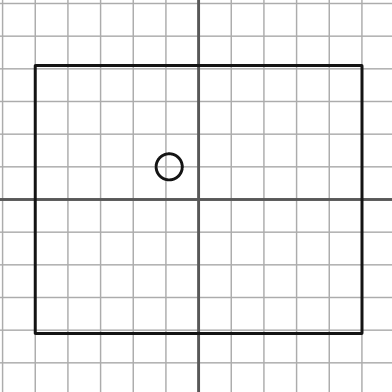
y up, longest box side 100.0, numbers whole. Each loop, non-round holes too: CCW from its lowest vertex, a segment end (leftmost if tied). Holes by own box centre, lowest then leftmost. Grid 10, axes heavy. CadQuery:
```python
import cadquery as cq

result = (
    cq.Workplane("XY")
    .moveTo(-50.0, -41.0)
    .lineTo(50.0, -41.0)
    .lineTo(50.0, 41.0)
    .lineTo(-50.0, 41.0)
    .close()
    .moveTo(-9.0, 10.0)
    .circle(4.0)
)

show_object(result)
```